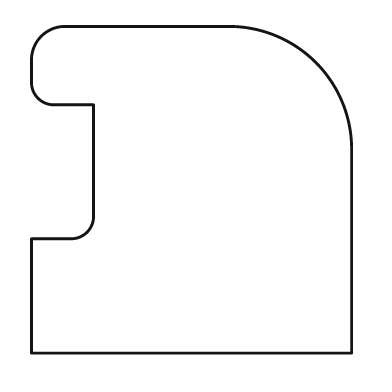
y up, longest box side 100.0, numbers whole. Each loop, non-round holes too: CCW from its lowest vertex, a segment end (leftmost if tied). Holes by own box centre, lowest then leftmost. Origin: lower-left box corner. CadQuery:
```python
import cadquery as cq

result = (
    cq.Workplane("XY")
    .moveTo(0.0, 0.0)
    .lineTo(98.0, 0.0)
    .lineTo(98.0, 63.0)
    .threePointArc((87.0, 89.0), (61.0, 100.0))
    .lineTo(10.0, 100.0)
    .threePointArc((3.0, 97.0), (0.0, 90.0))
    .lineTo(0.0, 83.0)
    .threePointArc((2.0, 78.0), (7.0, 76.0))
    .lineTo(19.0, 76.0)
    .lineTo(19.0, 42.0)
    .threePointArc((17.0, 37.0), (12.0, 35.0))
    .lineTo(0.0, 35.0)
    .close()
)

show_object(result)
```